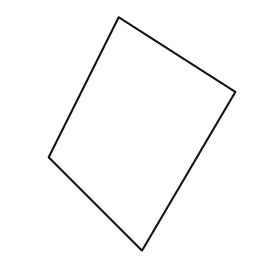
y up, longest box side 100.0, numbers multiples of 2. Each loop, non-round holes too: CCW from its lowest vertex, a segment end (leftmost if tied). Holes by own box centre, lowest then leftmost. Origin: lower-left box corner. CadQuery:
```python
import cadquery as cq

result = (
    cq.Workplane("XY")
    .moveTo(40.0, 0.0)
    .lineTo(80.0, 68.0)
    .lineTo(30.0, 100.0)
    .lineTo(0.0, 40.0)
    .close()
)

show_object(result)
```